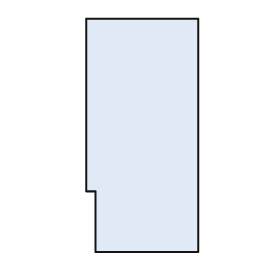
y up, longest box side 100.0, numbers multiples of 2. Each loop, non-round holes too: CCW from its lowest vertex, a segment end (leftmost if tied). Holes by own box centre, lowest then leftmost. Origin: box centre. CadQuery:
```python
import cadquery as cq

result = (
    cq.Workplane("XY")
    .moveTo(-20.0, -50.0)
    .lineTo(24.0, -50.0)
    .lineTo(24.0, 50.0)
    .lineTo(-24.0, 50.0)
    .lineTo(-24.0, -24.0)
    .lineTo(-20.0, -24.0)
    .close()
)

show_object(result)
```